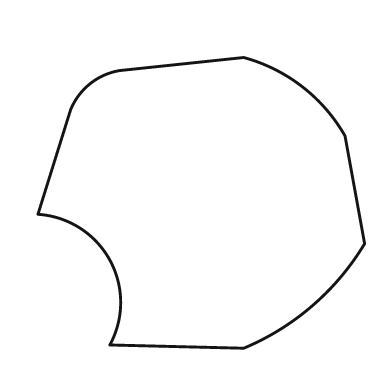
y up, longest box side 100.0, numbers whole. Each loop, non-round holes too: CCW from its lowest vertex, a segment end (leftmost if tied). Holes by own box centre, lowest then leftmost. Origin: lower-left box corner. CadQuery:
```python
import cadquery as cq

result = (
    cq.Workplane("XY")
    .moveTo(63.0, 0.0)
    .threePointArc((84.0, 13.0), (100.0, 32.0))
    .lineTo(94.0, 65.0)
    .threePointArc((81.0, 80.0), (63.0, 89.0))
    .lineTo(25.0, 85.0)
    .threePointArc((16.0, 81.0), (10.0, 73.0))
    .lineTo(0.0, 41.0)
    .threePointArc((22.0, 27.0), (22.0, 1.0))
    .close()
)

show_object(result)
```